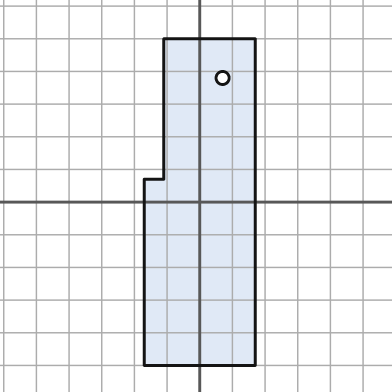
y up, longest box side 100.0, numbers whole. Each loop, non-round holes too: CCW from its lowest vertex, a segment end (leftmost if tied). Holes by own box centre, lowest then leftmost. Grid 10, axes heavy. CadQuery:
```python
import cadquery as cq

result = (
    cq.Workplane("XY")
    .moveTo(-17.0, -50.0)
    .lineTo(17.0, -50.0)
    .lineTo(17.0, 50.0)
    .lineTo(-11.0, 50.0)
    .lineTo(-11.0, 7.0)
    .lineTo(-17.0, 7.0)
    .close()
    .moveTo(7.0, 38.0)
    .circle(2.0)
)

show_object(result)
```